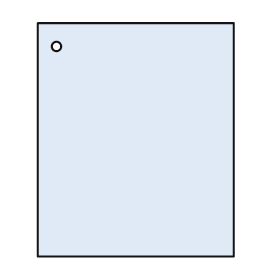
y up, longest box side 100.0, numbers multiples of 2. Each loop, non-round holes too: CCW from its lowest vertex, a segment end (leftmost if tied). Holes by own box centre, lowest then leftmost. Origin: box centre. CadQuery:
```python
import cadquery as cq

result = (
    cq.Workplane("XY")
    .moveTo(-42.0, -50.0)
    .lineTo(42.0, -50.0)
    .lineTo(42.0, 50.0)
    .lineTo(-42.0, 50.0)
    .close()
    .moveTo(-34.0, 40.0)
    .circle(2.0)
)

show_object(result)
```